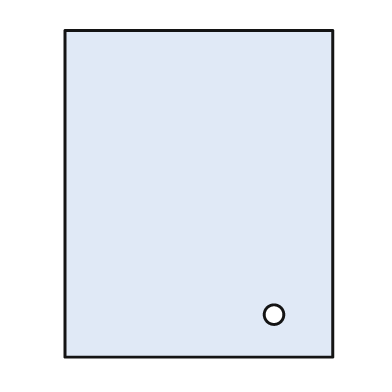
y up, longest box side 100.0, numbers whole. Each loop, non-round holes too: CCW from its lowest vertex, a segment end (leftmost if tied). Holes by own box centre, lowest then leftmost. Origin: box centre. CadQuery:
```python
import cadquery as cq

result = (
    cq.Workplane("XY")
    .moveTo(-41.0, -50.0)
    .lineTo(41.0, -50.0)
    .lineTo(41.0, 50.0)
    .lineTo(-41.0, 50.0)
    .close()
    .moveTo(23.0, -37.0)
    .circle(3.0)
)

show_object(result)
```